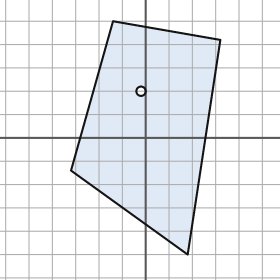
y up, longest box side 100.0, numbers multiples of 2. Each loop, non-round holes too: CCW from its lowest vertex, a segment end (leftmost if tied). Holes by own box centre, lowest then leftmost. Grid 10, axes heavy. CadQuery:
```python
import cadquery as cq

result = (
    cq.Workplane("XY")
    .moveTo(18.0, -50.0)
    .lineTo(32.0, 42.0)
    .lineTo(-14.0, 50.0)
    .lineTo(-32.0, -14.0)
    .close()
    .moveTo(-2.0, 20.0)
    .circle(2.0)
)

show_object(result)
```